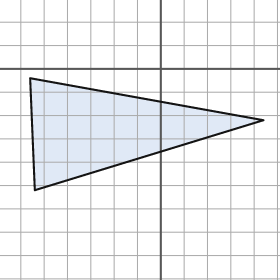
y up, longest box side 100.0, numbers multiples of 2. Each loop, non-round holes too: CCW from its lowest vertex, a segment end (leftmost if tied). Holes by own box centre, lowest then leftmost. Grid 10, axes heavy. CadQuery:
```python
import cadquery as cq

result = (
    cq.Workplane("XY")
    .moveTo(-54.0, -52.0)
    .lineTo(44.0, -22.0)
    .lineTo(-56.0, -4.0)
    .close()
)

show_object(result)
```